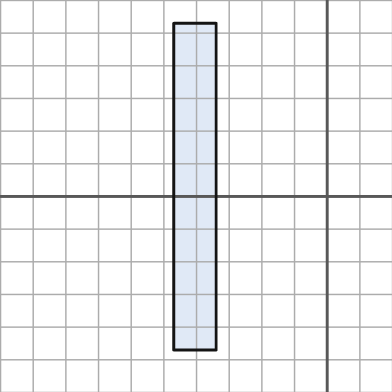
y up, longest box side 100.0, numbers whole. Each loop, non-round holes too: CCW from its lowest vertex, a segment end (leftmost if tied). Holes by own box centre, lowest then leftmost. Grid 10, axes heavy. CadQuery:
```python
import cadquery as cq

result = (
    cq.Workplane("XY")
    .moveTo(-47.0, -47.0)
    .lineTo(-34.0, -47.0)
    .lineTo(-34.0, 53.0)
    .lineTo(-47.0, 53.0)
    .close()
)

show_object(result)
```